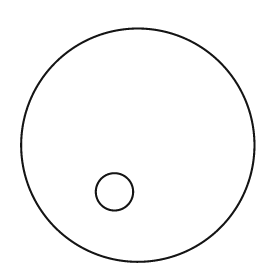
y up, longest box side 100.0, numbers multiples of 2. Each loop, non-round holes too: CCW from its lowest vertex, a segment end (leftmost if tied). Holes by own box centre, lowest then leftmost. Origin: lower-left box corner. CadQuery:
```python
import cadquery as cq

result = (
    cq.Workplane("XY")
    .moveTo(50.0, 50.0)
    .circle(50.0)
    .moveTo(40.0, 30.0)
    .circle(8.0)
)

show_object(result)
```